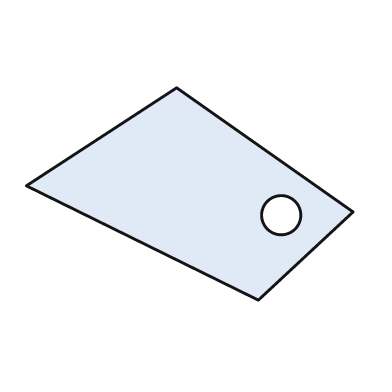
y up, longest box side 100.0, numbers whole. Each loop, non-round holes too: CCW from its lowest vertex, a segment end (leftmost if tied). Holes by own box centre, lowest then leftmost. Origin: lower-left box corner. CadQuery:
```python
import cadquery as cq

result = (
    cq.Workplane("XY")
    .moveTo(71.0, 0.0)
    .lineTo(100.0, 27.0)
    .lineTo(46.0, 65.0)
    .lineTo(0.0, 35.0)
    .close()
    .moveTo(78.0, 26.0)
    .circle(6.0)
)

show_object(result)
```